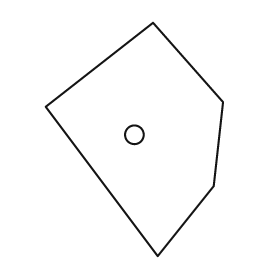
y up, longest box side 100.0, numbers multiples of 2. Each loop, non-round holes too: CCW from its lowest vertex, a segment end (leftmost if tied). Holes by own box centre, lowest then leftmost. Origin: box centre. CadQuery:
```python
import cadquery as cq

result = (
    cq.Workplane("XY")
    .moveTo(10.0, -50.0)
    .lineTo(34.0, -20.0)
    .lineTo(38.0, 16.0)
    .lineTo(8.0, 50.0)
    .lineTo(-38.0, 14.0)
    .close()
    .moveTo(0.0, 2.0)
    .circle(4.0)
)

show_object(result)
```